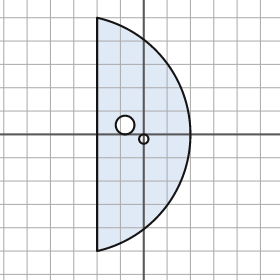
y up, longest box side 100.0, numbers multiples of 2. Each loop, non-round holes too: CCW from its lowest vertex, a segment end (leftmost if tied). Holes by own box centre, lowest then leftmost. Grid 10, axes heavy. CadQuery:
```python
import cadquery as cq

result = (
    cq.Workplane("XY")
    .moveTo(-20.0, -50.0)
    .threePointArc((20.0, 0.0), (-20.0, 50.0))
    .close()
    .moveTo(0.0, -2.0)
    .circle(2.0)
    .moveTo(-8.0, 4.0)
    .circle(4.0)
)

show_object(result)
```